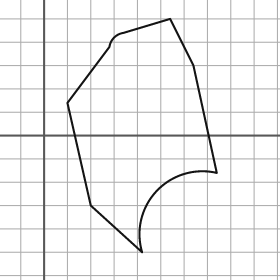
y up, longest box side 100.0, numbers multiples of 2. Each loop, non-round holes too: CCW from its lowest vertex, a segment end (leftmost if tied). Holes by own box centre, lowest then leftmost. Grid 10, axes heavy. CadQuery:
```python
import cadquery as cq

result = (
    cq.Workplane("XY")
    .moveTo(42.0, -50.0)
    .threePointArc((48.0, -24.0), (74.0, -16.0))
    .lineTo(64.0, 30.0)
    .lineTo(54.0, 50.0)
    .lineTo(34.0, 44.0)
    .threePointArc((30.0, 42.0), (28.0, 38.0))
    .lineTo(10.0, 14.0)
    .lineTo(20.0, -30.0)
    .close()
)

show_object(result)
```